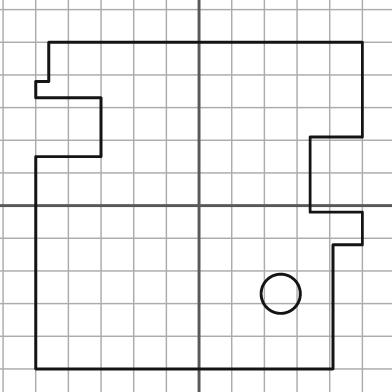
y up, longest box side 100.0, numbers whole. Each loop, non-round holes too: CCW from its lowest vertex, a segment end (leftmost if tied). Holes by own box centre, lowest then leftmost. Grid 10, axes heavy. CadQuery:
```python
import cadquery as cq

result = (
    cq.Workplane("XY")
    .moveTo(-50.0, -50.0)
    .lineTo(41.0, -50.0)
    .lineTo(41.0, -12.0)
    .lineTo(50.0, -12.0)
    .lineTo(50.0, -2.0)
    .lineTo(34.0, -2.0)
    .lineTo(34.0, 21.0)
    .lineTo(50.0, 21.0)
    .lineTo(50.0, 50.0)
    .lineTo(-46.0, 50.0)
    .lineTo(-46.0, 38.0)
    .lineTo(-50.0, 38.0)
    .lineTo(-50.0, 33.0)
    .lineTo(-30.0, 33.0)
    .lineTo(-30.0, 15.0)
    .lineTo(-50.0, 15.0)
    .close()
    .moveTo(25.0, -27.0)
    .circle(6.0)
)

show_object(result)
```